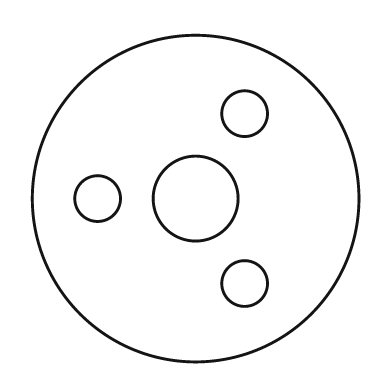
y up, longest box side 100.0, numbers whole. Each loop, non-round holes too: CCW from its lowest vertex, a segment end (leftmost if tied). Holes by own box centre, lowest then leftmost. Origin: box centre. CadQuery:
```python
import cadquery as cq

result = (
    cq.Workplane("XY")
    .moveTo(0.0, 0.0)
    .circle(50.0)
    .moveTo(15.0, -26.0)
    .circle(7.0)
    .moveTo(-30.0, 0.0)
    .circle(7.0)
    .moveTo(0.0, 0.0)
    .circle(13.0)
    .moveTo(15.0, 26.0)
    .circle(7.0)
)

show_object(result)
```